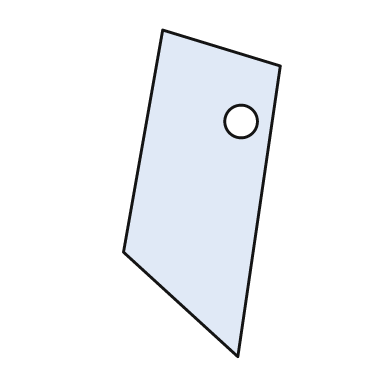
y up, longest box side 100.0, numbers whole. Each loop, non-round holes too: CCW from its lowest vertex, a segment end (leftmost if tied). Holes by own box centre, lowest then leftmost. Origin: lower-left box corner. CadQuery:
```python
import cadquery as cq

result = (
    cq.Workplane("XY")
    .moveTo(35.0, 0.0)
    .lineTo(48.0, 89.0)
    .lineTo(12.0, 100.0)
    .lineTo(0.0, 32.0)
    .close()
    .moveTo(36.0, 72.0)
    .circle(5.0)
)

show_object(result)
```